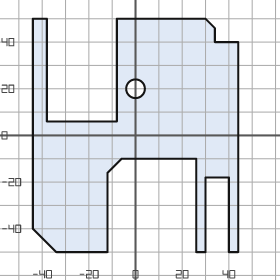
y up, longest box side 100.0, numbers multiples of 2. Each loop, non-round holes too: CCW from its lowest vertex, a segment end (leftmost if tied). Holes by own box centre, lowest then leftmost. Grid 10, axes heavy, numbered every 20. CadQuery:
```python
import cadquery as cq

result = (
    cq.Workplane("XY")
    .moveTo(-34.0, -50.0)
    .lineTo(-12.0, -50.0)
    .lineTo(-12.0, -16.0)
    .lineTo(-6.0, -10.0)
    .lineTo(26.0, -10.0)
    .lineTo(26.0, -50.0)
    .lineTo(30.0, -50.0)
    .lineTo(30.0, -18.0)
    .lineTo(40.0, -18.0)
    .lineTo(40.0, -50.0)
    .lineTo(44.0, -50.0)
    .lineTo(44.0, 40.0)
    .lineTo(34.0, 40.0)
    .lineTo(34.0, 46.0)
    .lineTo(30.0, 50.0)
    .lineTo(-8.0, 50.0)
    .lineTo(-8.0, 6.0)
    .lineTo(-38.0, 6.0)
    .lineTo(-38.0, 50.0)
    .lineTo(-44.0, 50.0)
    .lineTo(-44.0, -40.0)
    .close()
    .moveTo(0.0, 20.0)
    .circle(4.0)
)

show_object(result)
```